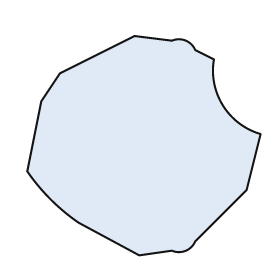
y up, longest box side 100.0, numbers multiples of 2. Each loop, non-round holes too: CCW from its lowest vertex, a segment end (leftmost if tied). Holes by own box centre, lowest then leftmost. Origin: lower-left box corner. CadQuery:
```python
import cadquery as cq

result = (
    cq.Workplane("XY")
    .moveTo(48.0, 0.0)
    .lineTo(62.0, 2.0)
    .threePointArc((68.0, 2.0), (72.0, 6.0))
    .lineTo(94.0, 28.0)
    .lineTo(100.0, 52.0)
    .threePointArc((84.0, 64.0), (80.0, 84.0))
    .lineTo(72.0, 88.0)
    .threePointArc((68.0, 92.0), (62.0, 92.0))
    .lineTo(46.0, 94.0)
    .lineTo(14.0, 78.0)
    .lineTo(6.0, 66.0)
    .lineTo(0.0, 36.0)
    .threePointArc((10.0, 24.0), (22.0, 14.0))
    .close()
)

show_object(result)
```